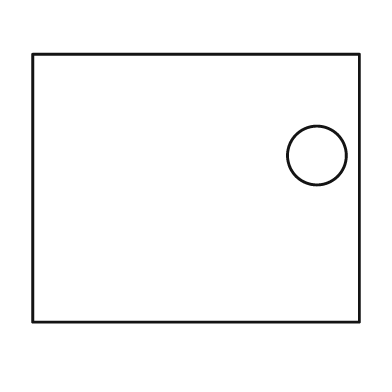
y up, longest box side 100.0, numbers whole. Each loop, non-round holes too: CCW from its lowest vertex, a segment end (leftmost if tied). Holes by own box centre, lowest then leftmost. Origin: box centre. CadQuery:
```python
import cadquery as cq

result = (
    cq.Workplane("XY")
    .moveTo(-50.0, -41.0)
    .lineTo(50.0, -41.0)
    .lineTo(50.0, 41.0)
    .lineTo(-50.0, 41.0)
    .close()
    .moveTo(37.0, 10.0)
    .circle(9.0)
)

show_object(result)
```